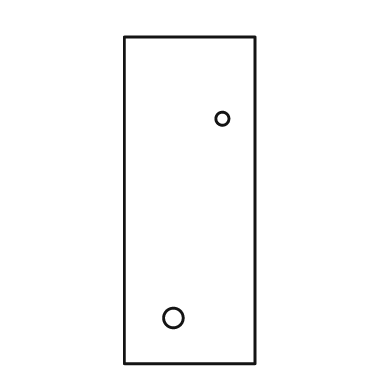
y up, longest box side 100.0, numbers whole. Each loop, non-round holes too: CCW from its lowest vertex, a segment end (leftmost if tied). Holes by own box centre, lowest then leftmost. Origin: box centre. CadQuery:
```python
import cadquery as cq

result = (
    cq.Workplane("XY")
    .moveTo(-20.0, -50.0)
    .lineTo(20.0, -50.0)
    .lineTo(20.0, 50.0)
    .lineTo(-20.0, 50.0)
    .close()
    .moveTo(-5.0, -36.0)
    .circle(3.0)
    .moveTo(10.0, 25.0)
    .circle(2.0)
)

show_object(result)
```